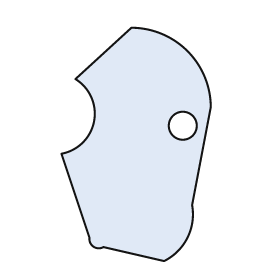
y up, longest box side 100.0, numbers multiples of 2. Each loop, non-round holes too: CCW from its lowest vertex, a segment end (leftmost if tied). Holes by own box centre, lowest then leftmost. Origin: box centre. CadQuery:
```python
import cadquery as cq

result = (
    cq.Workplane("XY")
    .moveTo(12.0, -50.0)
    .threePointArc((22.0, -40.0), (24.0, -26.0))
    .lineTo(32.0, 16.0)
    .threePointArc((22.0, 40.0), (-2.0, 50.0))
    .lineTo(-26.0, 28.0)
    .threePointArc((-18.0, 10.0), (-32.0, -4.0))
    .lineTo(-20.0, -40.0)
    .threePointArc((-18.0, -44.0), (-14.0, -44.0))
    .close()
    .moveTo(20.0, 8.0)
    .circle(6.0)
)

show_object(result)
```